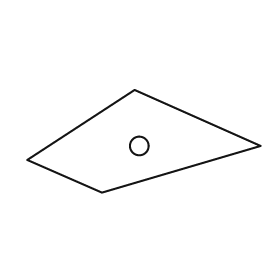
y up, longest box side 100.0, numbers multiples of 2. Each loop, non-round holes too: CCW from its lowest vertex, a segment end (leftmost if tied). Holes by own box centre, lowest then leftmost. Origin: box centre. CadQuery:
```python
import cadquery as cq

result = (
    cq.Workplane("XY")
    .moveTo(-18.0, -22.0)
    .lineTo(50.0, -2.0)
    .lineTo(-4.0, 22.0)
    .lineTo(-50.0, -8.0)
    .close()
    .moveTo(-2.0, -2.0)
    .circle(4.0)
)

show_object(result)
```